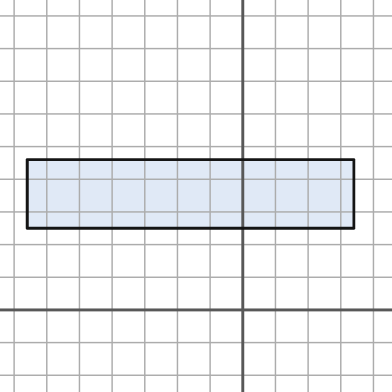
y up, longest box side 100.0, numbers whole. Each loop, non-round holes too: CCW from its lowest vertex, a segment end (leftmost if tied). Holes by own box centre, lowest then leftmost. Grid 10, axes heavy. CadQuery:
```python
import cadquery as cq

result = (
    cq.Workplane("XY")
    .moveTo(-66.0, 25.0)
    .lineTo(34.0, 25.0)
    .lineTo(34.0, 46.0)
    .lineTo(-66.0, 46.0)
    .close()
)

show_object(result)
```